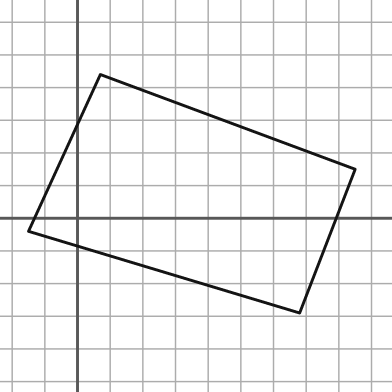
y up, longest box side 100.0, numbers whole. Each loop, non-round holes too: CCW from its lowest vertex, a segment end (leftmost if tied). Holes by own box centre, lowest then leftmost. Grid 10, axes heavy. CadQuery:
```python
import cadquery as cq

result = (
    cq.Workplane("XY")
    .moveTo(68.0, -29.0)
    .lineTo(85.0, 15.0)
    .lineTo(7.0, 44.0)
    .lineTo(-15.0, -4.0)
    .close()
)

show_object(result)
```